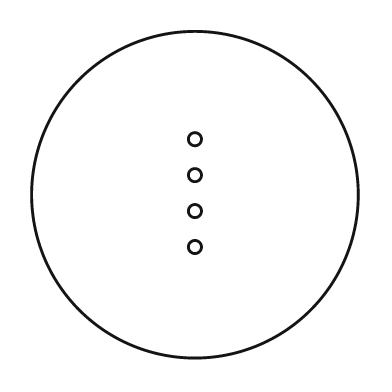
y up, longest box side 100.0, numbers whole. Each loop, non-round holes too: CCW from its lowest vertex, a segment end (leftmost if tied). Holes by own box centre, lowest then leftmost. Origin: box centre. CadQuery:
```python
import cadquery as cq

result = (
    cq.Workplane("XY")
    .moveTo(0.0, 0.0)
    .circle(50.0)
    .moveTo(0.0, -16.0)
    .circle(2.0)
    .moveTo(0.0, -5.0)
    .circle(2.0)
    .moveTo(0.0, 6.0)
    .circle(2.0)
    .moveTo(0.0, 17.0)
    .circle(2.0)
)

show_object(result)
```